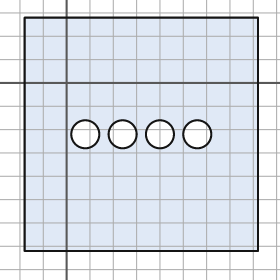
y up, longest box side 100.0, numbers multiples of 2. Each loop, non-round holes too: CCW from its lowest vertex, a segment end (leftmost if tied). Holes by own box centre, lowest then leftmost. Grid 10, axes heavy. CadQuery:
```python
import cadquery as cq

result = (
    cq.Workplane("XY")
    .moveTo(-18.0, -72.0)
    .lineTo(82.0, -72.0)
    .lineTo(82.0, 28.0)
    .lineTo(-18.0, 28.0)
    .close()
    .moveTo(8.0, -22.0)
    .circle(6.0)
    .moveTo(24.0, -22.0)
    .circle(6.0)
    .moveTo(40.0, -22.0)
    .circle(6.0)
    .moveTo(56.0, -22.0)
    .circle(6.0)
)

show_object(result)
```